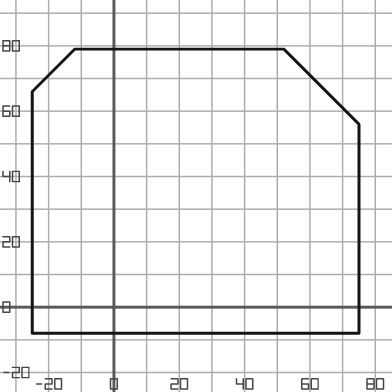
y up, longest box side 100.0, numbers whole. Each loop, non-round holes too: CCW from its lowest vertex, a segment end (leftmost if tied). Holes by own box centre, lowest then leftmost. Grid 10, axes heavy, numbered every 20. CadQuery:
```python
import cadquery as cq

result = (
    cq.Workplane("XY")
    .moveTo(-25.0, -8.0)
    .lineTo(75.0, -8.0)
    .lineTo(75.0, 56.0)
    .lineTo(52.0, 79.0)
    .lineTo(-12.0, 79.0)
    .lineTo(-25.0, 66.0)
    .close()
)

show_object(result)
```